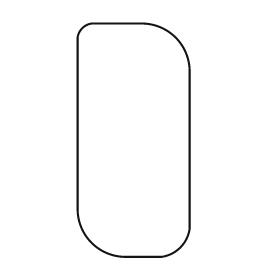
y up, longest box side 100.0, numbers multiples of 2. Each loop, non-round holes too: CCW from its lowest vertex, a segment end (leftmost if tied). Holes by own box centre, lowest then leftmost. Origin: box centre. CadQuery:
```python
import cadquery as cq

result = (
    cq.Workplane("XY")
    .moveTo(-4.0, -50.0)
    .lineTo(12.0, -50.0)
    .threePointArc((20.0, -46.0), (24.0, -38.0))
    .lineTo(24.0, 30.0)
    .threePointArc((18.0, 44.0), (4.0, 50.0))
    .lineTo(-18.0, 50.0)
    .threePointArc((-22.0, 48.0), (-24.0, 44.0))
    .lineTo(-24.0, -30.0)
    .threePointArc((-18.0, -44.0), (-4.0, -50.0))
    .close()
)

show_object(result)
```